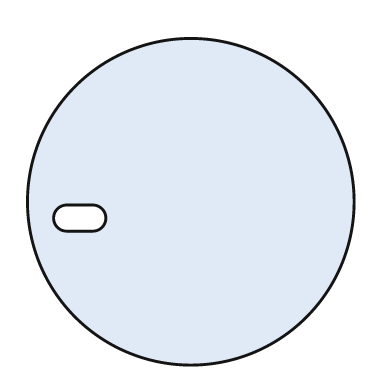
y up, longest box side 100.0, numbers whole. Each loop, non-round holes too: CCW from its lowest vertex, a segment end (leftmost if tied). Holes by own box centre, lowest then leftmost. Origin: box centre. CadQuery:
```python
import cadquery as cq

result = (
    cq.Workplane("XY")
    .moveTo(0.0, 0.0)
    .circle(50.0)
    .moveTo(-38.0, -9.0)
    .lineTo(-30.0, -9.0)
    .threePointArc((-26.0, -5.0), (-30.0, -1.0))
    .lineTo(-38.0, -1.0)
    .threePointArc((-42.0, -5.0), (-38.0, -9.0))
    .close()
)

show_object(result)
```